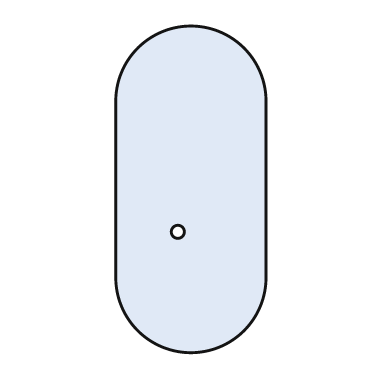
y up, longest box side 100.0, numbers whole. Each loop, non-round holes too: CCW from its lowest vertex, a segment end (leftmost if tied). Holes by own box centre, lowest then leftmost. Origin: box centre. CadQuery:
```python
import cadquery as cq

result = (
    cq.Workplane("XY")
    .moveTo(-23.0, -27.0)
    .threePointArc((0.0, -50.0), (23.0, -27.0))
    .lineTo(23.0, 27.0)
    .threePointArc((0.0, 50.0), (-23.0, 27.0))
    .close()
    .moveTo(-4.0, -13.0)
    .circle(2.0)
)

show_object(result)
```